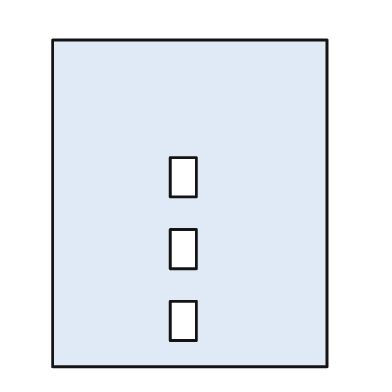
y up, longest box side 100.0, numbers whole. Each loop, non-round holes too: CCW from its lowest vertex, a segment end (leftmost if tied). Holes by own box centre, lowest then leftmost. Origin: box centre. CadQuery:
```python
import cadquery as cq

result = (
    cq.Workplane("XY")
    .moveTo(-42.0, -50.0)
    .lineTo(42.0, -50.0)
    .lineTo(42.0, 50.0)
    .lineTo(-42.0, 50.0)
    .close()
    .moveTo(-6.0, -42.0)
    .lineTo(2.0, -42.0)
    .lineTo(2.0, -30.0)
    .lineTo(-6.0, -30.0)
    .close()
    .moveTo(-6.0, -20.0)
    .lineTo(2.0, -20.0)
    .lineTo(2.0, -8.0)
    .lineTo(-6.0, -8.0)
    .close()
    .moveTo(-6.0, 2.0)
    .lineTo(2.0, 2.0)
    .lineTo(2.0, 14.0)
    .lineTo(-6.0, 14.0)
    .close()
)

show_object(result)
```